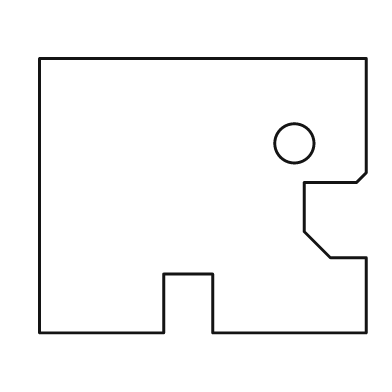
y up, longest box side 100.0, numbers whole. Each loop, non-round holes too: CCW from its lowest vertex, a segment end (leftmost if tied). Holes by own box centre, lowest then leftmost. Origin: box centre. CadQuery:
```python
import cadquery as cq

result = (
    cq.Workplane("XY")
    .moveTo(-50.0, -42.0)
    .lineTo(-12.0, -42.0)
    .lineTo(-12.0, -24.0)
    .lineTo(3.0, -24.0)
    .lineTo(3.0, -42.0)
    .lineTo(50.0, -42.0)
    .lineTo(50.0, -19.0)
    .lineTo(39.0, -19.0)
    .lineTo(31.0, -11.0)
    .lineTo(31.0, 4.0)
    .lineTo(47.0, 4.0)
    .lineTo(50.0, 7.0)
    .lineTo(50.0, 42.0)
    .lineTo(-50.0, 42.0)
    .close()
    .moveTo(28.0, 16.0)
    .circle(6.0)
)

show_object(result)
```